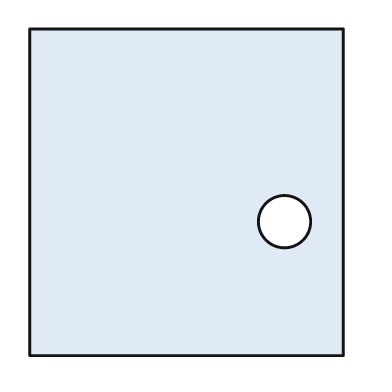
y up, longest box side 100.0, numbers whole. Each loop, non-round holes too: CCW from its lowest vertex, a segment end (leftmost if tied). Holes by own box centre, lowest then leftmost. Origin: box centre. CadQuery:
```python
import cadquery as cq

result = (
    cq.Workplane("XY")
    .moveTo(-48.0, -50.0)
    .lineTo(48.0, -50.0)
    .lineTo(48.0, 50.0)
    .lineTo(-48.0, 50.0)
    .close()
    .moveTo(30.0, -9.0)
    .circle(8.0)
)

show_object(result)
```